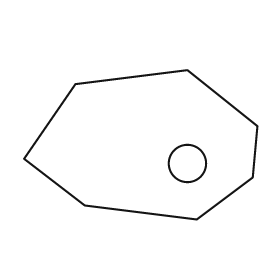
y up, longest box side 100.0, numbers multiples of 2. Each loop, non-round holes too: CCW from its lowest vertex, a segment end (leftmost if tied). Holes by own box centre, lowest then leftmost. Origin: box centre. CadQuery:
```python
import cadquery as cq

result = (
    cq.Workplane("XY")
    .moveTo(24.0, -32.0)
    .lineTo(48.0, -14.0)
    .lineTo(50.0, 8.0)
    .lineTo(20.0, 32.0)
    .lineTo(-28.0, 26.0)
    .lineTo(-50.0, -6.0)
    .lineTo(-24.0, -26.0)
    .close()
    .moveTo(20.0, -8.0)
    .circle(8.0)
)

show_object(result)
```